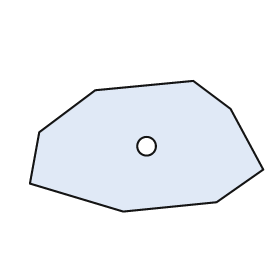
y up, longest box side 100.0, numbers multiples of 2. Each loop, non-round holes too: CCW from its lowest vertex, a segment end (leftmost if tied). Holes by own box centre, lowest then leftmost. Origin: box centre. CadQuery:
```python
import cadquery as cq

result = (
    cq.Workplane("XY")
    .moveTo(-10.0, -28.0)
    .lineTo(30.0, -24.0)
    .lineTo(50.0, -10.0)
    .lineTo(36.0, 16.0)
    .lineTo(20.0, 28.0)
    .lineTo(-22.0, 24.0)
    .lineTo(-46.0, 6.0)
    .lineTo(-50.0, -16.0)
    .close()
    .moveTo(0.0, 0.0)
    .circle(4.0)
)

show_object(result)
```